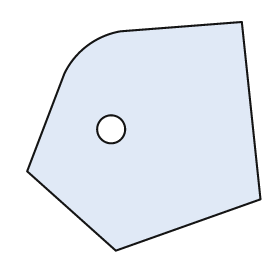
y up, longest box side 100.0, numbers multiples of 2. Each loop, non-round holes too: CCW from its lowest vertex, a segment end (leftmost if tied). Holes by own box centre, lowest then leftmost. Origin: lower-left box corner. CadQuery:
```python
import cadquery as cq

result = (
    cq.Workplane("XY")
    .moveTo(38.0, 0.0)
    .lineTo(100.0, 22.0)
    .lineTo(92.0, 98.0)
    .lineTo(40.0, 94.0)
    .threePointArc((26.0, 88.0), (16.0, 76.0))
    .lineTo(0.0, 34.0)
    .close()
    .moveTo(36.0, 52.0)
    .circle(6.0)
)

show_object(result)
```